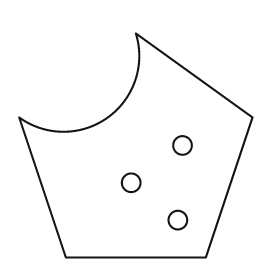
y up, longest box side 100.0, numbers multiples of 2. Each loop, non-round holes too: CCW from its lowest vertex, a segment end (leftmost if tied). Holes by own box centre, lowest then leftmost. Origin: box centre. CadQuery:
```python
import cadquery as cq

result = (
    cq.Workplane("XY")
    .moveTo(-30.0, -48.0)
    .lineTo(30.0, -48.0)
    .lineTo(50.0, 12.0)
    .lineTo(0.0, 48.0)
    .threePointArc((-12.0, 12.0), (-50.0, 12.0))
    .close()
    .moveTo(18.0, -32.0)
    .circle(4.0)
    .moveTo(-2.0, -16.0)
    .circle(4.0)
    .moveTo(20.0, 0.0)
    .circle(4.0)
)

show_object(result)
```